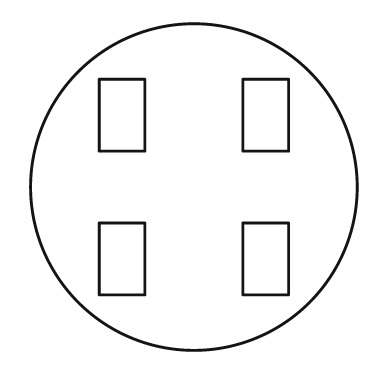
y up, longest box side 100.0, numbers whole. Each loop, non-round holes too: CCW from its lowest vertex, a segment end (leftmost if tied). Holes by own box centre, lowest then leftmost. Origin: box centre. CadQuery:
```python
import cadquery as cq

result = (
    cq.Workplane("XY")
    .moveTo(0.0, 0.0)
    .circle(50.0)
    .moveTo(-29.0, -33.0)
    .lineTo(-15.0, -33.0)
    .lineTo(-15.0, -11.0)
    .lineTo(-29.0, -11.0)
    .close()
    .moveTo(15.0, -33.0)
    .lineTo(29.0, -33.0)
    .lineTo(29.0, -11.0)
    .lineTo(15.0, -11.0)
    .close()
    .moveTo(-29.0, 11.0)
    .lineTo(-15.0, 11.0)
    .lineTo(-15.0, 33.0)
    .lineTo(-29.0, 33.0)
    .close()
    .moveTo(15.0, 11.0)
    .lineTo(29.0, 11.0)
    .lineTo(29.0, 33.0)
    .lineTo(15.0, 33.0)
    .close()
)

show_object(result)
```